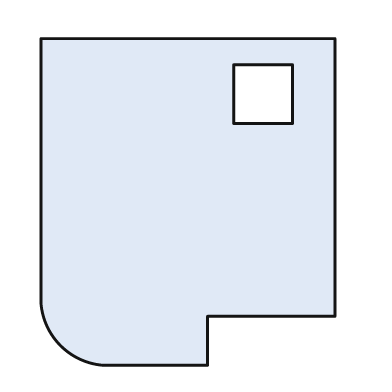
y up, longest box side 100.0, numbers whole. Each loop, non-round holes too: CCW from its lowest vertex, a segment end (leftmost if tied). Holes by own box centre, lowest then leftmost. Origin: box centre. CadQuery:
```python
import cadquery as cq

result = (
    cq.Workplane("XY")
    .moveTo(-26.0, -50.0)
    .lineTo(6.0, -50.0)
    .lineTo(6.0, -35.0)
    .lineTo(45.0, -35.0)
    .lineTo(45.0, 50.0)
    .lineTo(-45.0, 50.0)
    .lineTo(-45.0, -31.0)
    .threePointArc((-39.0, -44.0), (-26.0, -50.0))
    .close()
    .moveTo(14.0, 24.0)
    .lineTo(32.0, 24.0)
    .lineTo(32.0, 42.0)
    .lineTo(14.0, 42.0)
    .close()
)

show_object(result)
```